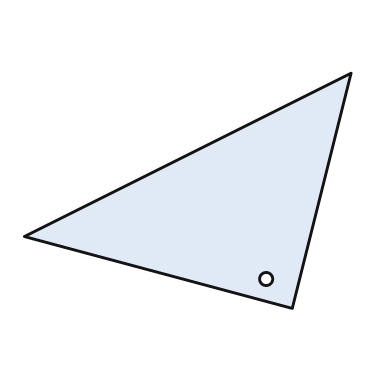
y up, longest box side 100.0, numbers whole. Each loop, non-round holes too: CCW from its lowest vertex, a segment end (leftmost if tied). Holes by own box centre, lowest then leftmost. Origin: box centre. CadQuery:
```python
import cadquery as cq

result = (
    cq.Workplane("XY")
    .moveTo(32.0, -36.0)
    .lineTo(50.0, 36.0)
    .lineTo(-50.0, -14.0)
    .close()
    .moveTo(24.0, -27.0)
    .circle(2.0)
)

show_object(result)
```